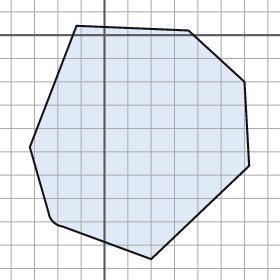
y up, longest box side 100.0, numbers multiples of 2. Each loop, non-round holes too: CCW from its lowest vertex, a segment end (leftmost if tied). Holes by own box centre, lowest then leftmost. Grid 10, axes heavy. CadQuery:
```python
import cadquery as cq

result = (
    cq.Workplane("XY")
    .moveTo(20.0, -96.0)
    .lineTo(62.0, -56.0)
    .lineTo(60.0, -20.0)
    .lineTo(36.0, 2.0)
    .lineTo(-12.0, 4.0)
    .lineTo(-32.0, -48.0)
    .lineTo(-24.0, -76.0)
    .threePointArc((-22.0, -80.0), (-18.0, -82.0))
    .close()
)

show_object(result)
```